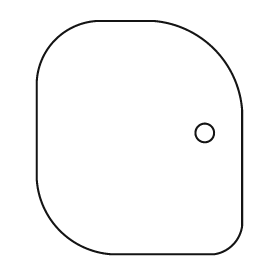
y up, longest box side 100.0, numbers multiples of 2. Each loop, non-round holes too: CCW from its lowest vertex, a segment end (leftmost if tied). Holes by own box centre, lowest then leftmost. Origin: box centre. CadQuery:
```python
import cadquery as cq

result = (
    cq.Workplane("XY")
    .moveTo(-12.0, -50.0)
    .lineTo(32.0, -50.0)
    .threePointArc((40.0, -46.0), (44.0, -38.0))
    .lineTo(44.0, 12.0)
    .threePointArc((32.0, 38.0), (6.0, 50.0))
    .lineTo(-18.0, 50.0)
    .threePointArc((-36.0, 42.0), (-44.0, 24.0))
    .lineTo(-44.0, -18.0)
    .threePointArc((-34.0, -40.0), (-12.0, -50.0))
    .close()
    .moveTo(28.0, 2.0)
    .circle(4.0)
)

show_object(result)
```